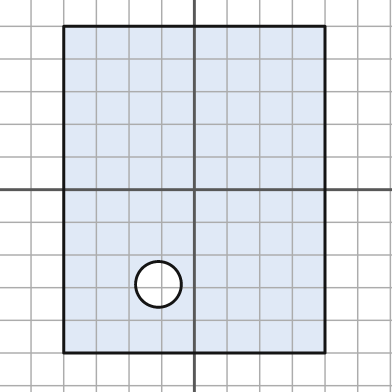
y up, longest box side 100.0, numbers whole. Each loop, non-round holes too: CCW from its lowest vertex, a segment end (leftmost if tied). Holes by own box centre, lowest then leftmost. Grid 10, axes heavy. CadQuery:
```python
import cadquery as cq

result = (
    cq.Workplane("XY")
    .moveTo(-40.0, -50.0)
    .lineTo(40.0, -50.0)
    .lineTo(40.0, 50.0)
    .lineTo(-40.0, 50.0)
    .close()
    .moveTo(-11.0, -29.0)
    .circle(7.0)
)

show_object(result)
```